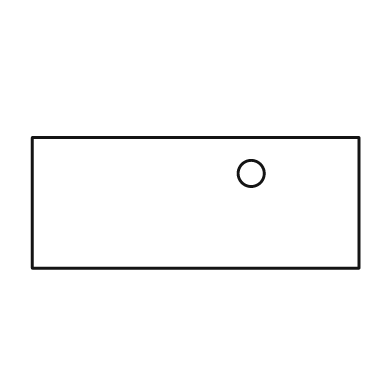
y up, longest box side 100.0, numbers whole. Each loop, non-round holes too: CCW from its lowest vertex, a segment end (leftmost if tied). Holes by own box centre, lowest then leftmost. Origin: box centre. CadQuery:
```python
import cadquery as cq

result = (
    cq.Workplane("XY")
    .moveTo(-50.0, -20.0)
    .lineTo(50.0, -20.0)
    .lineTo(50.0, 20.0)
    .lineTo(-50.0, 20.0)
    .close()
    .moveTo(17.0, 9.0)
    .circle(4.0)
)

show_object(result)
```